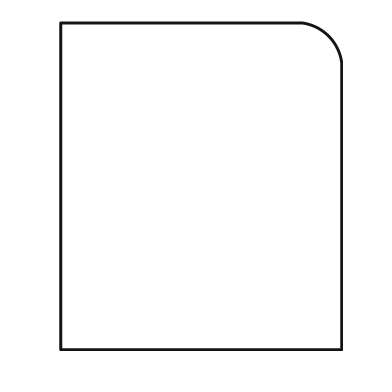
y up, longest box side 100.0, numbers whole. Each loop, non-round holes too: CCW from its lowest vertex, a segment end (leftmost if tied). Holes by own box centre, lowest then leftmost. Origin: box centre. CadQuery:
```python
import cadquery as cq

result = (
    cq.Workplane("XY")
    .moveTo(-43.0, -50.0)
    .lineTo(43.0, -50.0)
    .lineTo(43.0, 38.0)
    .threePointArc((39.0, 46.0), (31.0, 50.0))
    .lineTo(-43.0, 50.0)
    .close()
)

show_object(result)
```